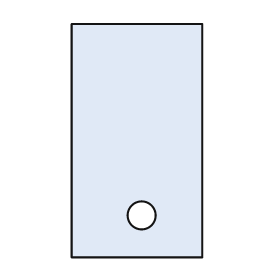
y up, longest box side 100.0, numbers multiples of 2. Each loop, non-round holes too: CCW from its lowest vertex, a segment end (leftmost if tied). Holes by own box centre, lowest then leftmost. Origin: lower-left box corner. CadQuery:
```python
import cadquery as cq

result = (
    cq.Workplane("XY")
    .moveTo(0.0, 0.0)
    .lineTo(56.0, 0.0)
    .lineTo(56.0, 100.0)
    .lineTo(0.0, 100.0)
    .close()
    .moveTo(30.0, 18.0)
    .circle(6.0)
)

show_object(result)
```